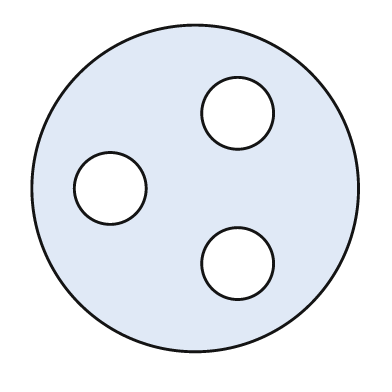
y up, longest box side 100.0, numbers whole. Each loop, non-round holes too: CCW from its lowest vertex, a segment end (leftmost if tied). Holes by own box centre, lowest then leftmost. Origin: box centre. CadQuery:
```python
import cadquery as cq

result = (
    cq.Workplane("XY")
    .moveTo(0.0, 0.0)
    .circle(50.0)
    .moveTo(13.0, -23.0)
    .circle(11.0)
    .moveTo(-26.0, 0.0)
    .circle(11.0)
    .moveTo(13.0, 23.0)
    .circle(11.0)
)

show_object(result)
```